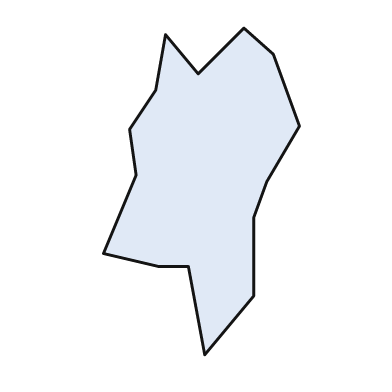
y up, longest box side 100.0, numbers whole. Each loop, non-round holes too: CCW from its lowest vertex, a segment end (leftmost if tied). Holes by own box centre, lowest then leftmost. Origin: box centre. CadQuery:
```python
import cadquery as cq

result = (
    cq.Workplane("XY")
    .moveTo(1.0, -50.0)
    .lineTo(16.0, -32.0)
    .lineTo(16.0, -8.0)
    .lineTo(20.0, 3.0)
    .lineTo(30.0, 20.0)
    .lineTo(22.0, 42.0)
    .lineTo(13.0, 50.0)
    .lineTo(-1.0, 36.0)
    .lineTo(-11.0, 48.0)
    .lineTo(-14.0, 31.0)
    .lineTo(-22.0, 19.0)
    .lineTo(-20.0, 5.0)
    .lineTo(-30.0, -19.0)
    .lineTo(-13.0, -23.0)
    .lineTo(-4.0, -23.0)
    .close()
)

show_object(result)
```